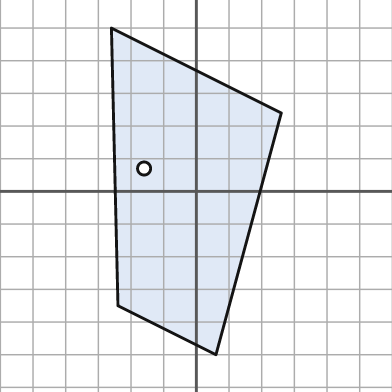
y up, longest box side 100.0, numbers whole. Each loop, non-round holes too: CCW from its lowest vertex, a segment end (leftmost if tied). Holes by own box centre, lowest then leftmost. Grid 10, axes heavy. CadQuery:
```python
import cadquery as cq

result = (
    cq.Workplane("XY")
    .moveTo(6.0, -50.0)
    .lineTo(26.0, 24.0)
    .lineTo(-26.0, 50.0)
    .lineTo(-24.0, -35.0)
    .close()
    .moveTo(-16.0, 7.0)
    .circle(2.0)
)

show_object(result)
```